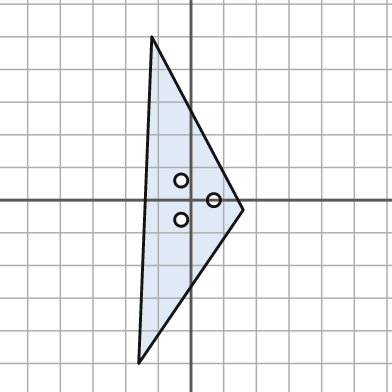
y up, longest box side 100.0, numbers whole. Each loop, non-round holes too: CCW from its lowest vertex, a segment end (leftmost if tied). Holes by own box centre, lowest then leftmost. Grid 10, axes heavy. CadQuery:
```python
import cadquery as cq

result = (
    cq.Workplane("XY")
    .moveTo(-16.0, -50.0)
    .lineTo(16.0, -3.0)
    .lineTo(-12.0, 50.0)
    .close()
    .moveTo(-3.0, -6.0)
    .circle(2.0)
    .moveTo(7.0, 0.0)
    .circle(2.0)
    .moveTo(-3.0, 6.0)
    .circle(2.0)
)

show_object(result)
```